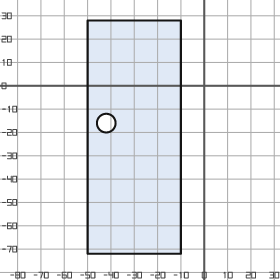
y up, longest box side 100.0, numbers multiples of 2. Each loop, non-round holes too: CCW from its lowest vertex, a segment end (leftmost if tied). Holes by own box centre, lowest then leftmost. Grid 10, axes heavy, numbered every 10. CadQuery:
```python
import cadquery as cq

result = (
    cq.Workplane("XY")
    .moveTo(-50.0, -72.0)
    .lineTo(-10.0, -72.0)
    .lineTo(-10.0, 28.0)
    .lineTo(-50.0, 28.0)
    .close()
    .moveTo(-42.0, -16.0)
    .circle(4.0)
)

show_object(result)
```